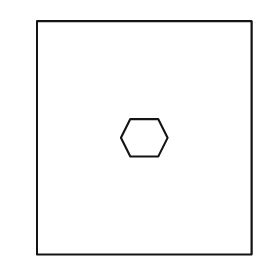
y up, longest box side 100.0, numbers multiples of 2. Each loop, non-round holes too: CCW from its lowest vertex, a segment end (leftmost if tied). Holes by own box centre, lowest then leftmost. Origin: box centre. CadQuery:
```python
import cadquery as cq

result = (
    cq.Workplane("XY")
    .moveTo(-46.0, -50.0)
    .lineTo(46.0, -50.0)
    .lineTo(46.0, 50.0)
    .lineTo(-46.0, 50.0)
    .close()
    .moveTo(-6.0, -8.0)
    .lineTo(6.0, -8.0)
    .lineTo(10.0, 0.0)
    .lineTo(6.0, 8.0)
    .lineTo(-6.0, 8.0)
    .lineTo(-10.0, 0.0)
    .close()
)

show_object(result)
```